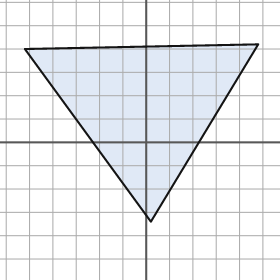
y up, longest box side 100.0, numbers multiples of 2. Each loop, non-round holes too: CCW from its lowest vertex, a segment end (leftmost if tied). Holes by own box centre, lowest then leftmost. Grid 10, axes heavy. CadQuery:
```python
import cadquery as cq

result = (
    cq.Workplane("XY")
    .moveTo(2.0, -34.0)
    .lineTo(48.0, 42.0)
    .lineTo(-52.0, 40.0)
    .close()
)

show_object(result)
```